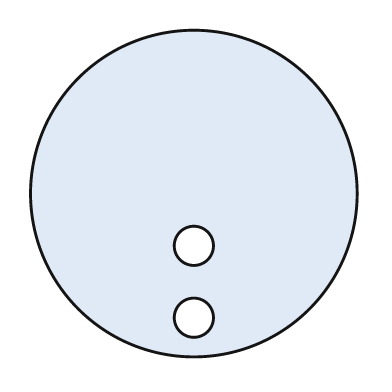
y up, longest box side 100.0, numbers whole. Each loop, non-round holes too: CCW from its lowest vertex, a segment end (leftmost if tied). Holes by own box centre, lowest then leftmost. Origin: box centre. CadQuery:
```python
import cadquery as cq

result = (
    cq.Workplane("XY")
    .moveTo(0.0, 0.0)
    .circle(50.0)
    .moveTo(0.0, -38.0)
    .circle(6.0)
    .moveTo(0.0, -16.0)
    .circle(6.0)
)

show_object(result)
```